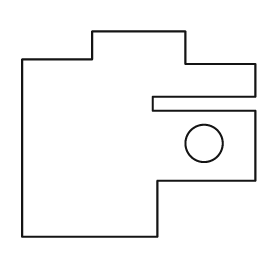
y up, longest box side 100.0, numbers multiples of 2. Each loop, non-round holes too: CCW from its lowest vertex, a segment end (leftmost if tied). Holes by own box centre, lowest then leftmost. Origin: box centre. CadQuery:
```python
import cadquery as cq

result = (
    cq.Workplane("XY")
    .moveTo(-50.0, -44.0)
    .lineTo(8.0, -44.0)
    .lineTo(8.0, -20.0)
    .lineTo(50.0, -20.0)
    .lineTo(50.0, 10.0)
    .lineTo(6.0, 10.0)
    .lineTo(6.0, 16.0)
    .lineTo(50.0, 16.0)
    .lineTo(50.0, 30.0)
    .lineTo(20.0, 30.0)
    .lineTo(20.0, 44.0)
    .lineTo(-20.0, 44.0)
    .lineTo(-20.0, 32.0)
    .lineTo(-50.0, 32.0)
    .close()
    .moveTo(28.0, -4.0)
    .circle(8.0)
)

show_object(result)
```